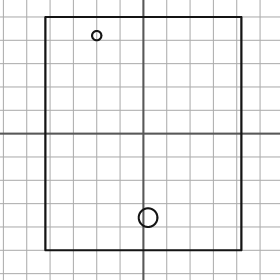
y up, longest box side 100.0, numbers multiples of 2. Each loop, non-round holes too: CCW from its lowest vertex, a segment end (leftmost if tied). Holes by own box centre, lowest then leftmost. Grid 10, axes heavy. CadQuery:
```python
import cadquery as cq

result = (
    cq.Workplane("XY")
    .moveTo(-42.0, -50.0)
    .lineTo(42.0, -50.0)
    .lineTo(42.0, 50.0)
    .lineTo(-42.0, 50.0)
    .close()
    .moveTo(2.0, -36.0)
    .circle(4.0)
    .moveTo(-20.0, 42.0)
    .circle(2.0)
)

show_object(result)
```